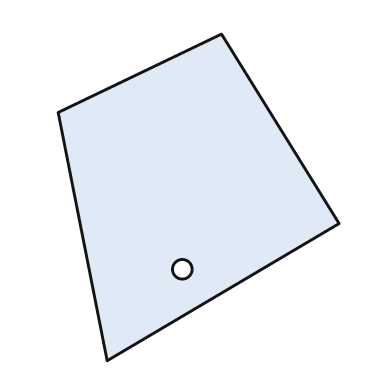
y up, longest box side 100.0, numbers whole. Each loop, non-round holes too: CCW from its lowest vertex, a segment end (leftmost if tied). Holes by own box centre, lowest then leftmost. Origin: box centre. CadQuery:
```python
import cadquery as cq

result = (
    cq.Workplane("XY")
    .moveTo(-28.0, -50.0)
    .lineTo(43.0, -8.0)
    .lineTo(7.0, 50.0)
    .lineTo(-43.0, 26.0)
    .close()
    .moveTo(-5.0, -22.0)
    .circle(3.0)
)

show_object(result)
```